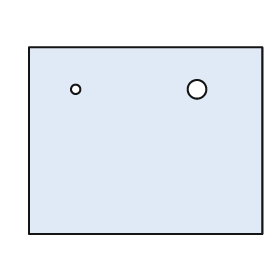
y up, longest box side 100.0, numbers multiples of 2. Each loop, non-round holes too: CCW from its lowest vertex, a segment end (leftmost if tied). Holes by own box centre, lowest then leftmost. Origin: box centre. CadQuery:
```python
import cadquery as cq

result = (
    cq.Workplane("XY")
    .moveTo(-50.0, -40.0)
    .lineTo(50.0, -40.0)
    .lineTo(50.0, 40.0)
    .lineTo(-50.0, 40.0)
    .close()
    .moveTo(-30.0, 22.0)
    .circle(2.0)
    .moveTo(22.0, 22.0)
    .circle(4.0)
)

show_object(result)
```